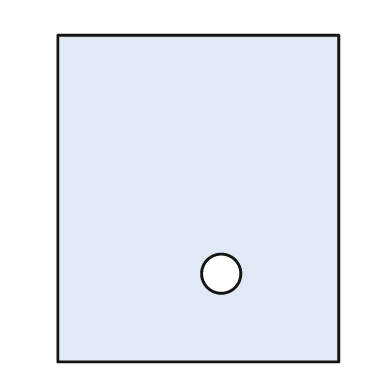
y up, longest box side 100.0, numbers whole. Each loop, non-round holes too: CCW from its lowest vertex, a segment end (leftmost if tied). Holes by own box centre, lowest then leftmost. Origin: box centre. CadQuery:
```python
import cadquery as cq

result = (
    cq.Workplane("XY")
    .moveTo(-43.0, -50.0)
    .lineTo(43.0, -50.0)
    .lineTo(43.0, 50.0)
    .lineTo(-43.0, 50.0)
    .close()
    .moveTo(7.0, -23.0)
    .circle(6.0)
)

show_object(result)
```